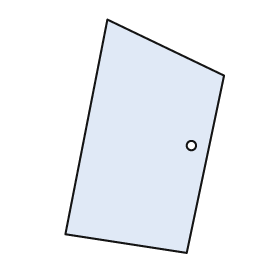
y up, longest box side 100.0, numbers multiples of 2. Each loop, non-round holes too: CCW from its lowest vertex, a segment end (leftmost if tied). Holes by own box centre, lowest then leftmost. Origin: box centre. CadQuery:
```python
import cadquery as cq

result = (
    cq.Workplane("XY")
    .moveTo(18.0, -50.0)
    .lineTo(34.0, 26.0)
    .lineTo(-16.0, 50.0)
    .lineTo(-34.0, -42.0)
    .close()
    .moveTo(20.0, -4.0)
    .circle(2.0)
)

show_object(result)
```